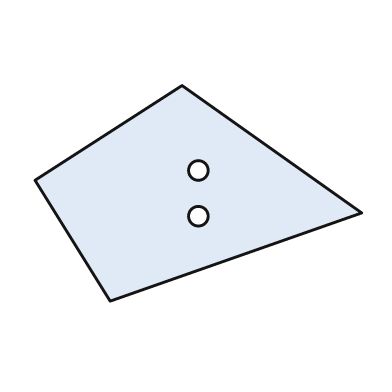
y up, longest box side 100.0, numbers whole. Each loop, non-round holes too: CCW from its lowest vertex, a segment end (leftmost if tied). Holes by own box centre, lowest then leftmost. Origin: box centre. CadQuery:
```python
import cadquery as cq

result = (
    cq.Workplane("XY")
    .moveTo(-27.0, -33.0)
    .lineTo(50.0, -6.0)
    .lineTo(-5.0, 33.0)
    .lineTo(-50.0, 4.0)
    .close()
    .moveTo(0.0, -7.0)
    .circle(3.0)
    .moveTo(0.0, 7.0)
    .circle(3.0)
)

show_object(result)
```